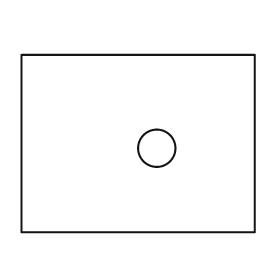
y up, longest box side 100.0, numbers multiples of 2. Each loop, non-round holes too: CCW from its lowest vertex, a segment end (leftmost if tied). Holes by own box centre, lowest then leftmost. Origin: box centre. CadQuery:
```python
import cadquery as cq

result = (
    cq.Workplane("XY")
    .moveTo(-50.0, -38.0)
    .lineTo(50.0, -38.0)
    .lineTo(50.0, 38.0)
    .lineTo(-50.0, 38.0)
    .close()
    .moveTo(8.0, -2.0)
    .circle(8.0)
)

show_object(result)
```